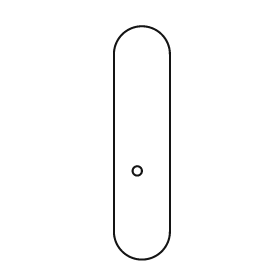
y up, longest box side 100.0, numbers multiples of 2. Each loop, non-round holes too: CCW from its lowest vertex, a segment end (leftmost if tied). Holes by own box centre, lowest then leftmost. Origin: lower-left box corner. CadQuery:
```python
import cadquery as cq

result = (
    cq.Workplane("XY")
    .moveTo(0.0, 12.0)
    .threePointArc((12.0, 0.0), (24.0, 12.0))
    .lineTo(24.0, 88.0)
    .threePointArc((12.0, 100.0), (0.0, 88.0))
    .close()
    .moveTo(10.0, 38.0)
    .circle(2.0)
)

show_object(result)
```